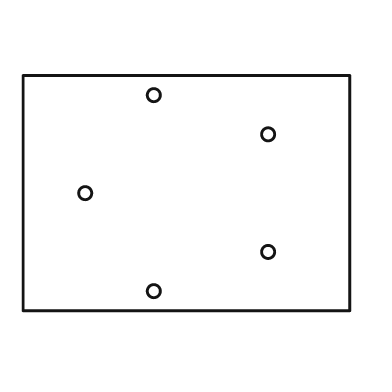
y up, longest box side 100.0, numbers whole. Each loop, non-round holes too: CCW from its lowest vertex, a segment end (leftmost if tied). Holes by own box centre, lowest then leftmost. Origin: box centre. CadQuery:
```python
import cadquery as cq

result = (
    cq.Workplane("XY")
    .moveTo(-50.0, -36.0)
    .lineTo(50.0, -36.0)
    .lineTo(50.0, 36.0)
    .lineTo(-50.0, 36.0)
    .close()
    .moveTo(-10.0, -30.0)
    .circle(2.0)
    .moveTo(25.0, -18.0)
    .circle(2.0)
    .moveTo(-31.0, 0.0)
    .circle(2.0)
    .moveTo(25.0, 18.0)
    .circle(2.0)
    .moveTo(-10.0, 30.0)
    .circle(2.0)
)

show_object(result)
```